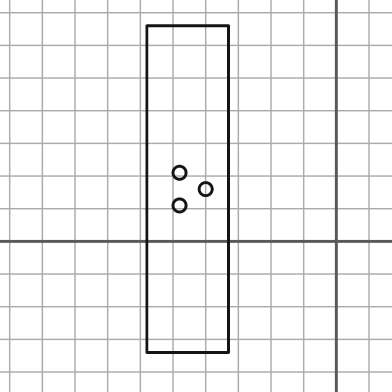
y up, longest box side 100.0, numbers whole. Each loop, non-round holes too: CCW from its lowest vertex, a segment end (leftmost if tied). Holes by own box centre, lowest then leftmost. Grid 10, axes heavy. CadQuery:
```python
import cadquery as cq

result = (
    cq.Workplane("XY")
    .moveTo(-58.0, -34.0)
    .lineTo(-33.0, -34.0)
    .lineTo(-33.0, 66.0)
    .lineTo(-58.0, 66.0)
    .close()
    .moveTo(-48.0, 11.0)
    .circle(2.0)
    .moveTo(-40.0, 16.0)
    .circle(2.0)
    .moveTo(-48.0, 21.0)
    .circle(2.0)
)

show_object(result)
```